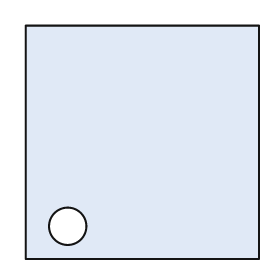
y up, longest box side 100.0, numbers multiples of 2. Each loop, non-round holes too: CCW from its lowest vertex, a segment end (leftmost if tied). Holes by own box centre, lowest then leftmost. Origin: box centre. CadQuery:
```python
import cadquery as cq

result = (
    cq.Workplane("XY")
    .moveTo(-50.0, -50.0)
    .lineTo(50.0, -50.0)
    .lineTo(50.0, 50.0)
    .lineTo(-50.0, 50.0)
    .close()
    .moveTo(-32.0, -36.0)
    .circle(8.0)
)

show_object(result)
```